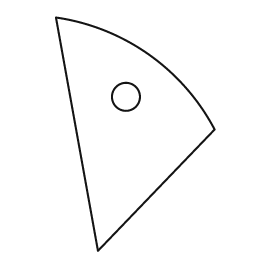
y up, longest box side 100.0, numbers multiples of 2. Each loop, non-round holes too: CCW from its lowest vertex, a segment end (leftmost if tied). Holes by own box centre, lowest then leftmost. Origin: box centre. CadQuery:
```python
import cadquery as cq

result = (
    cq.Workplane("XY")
    .moveTo(-16.0, -50.0)
    .lineTo(34.0, 2.0)
    .threePointArc((6.0, 34.0), (-34.0, 50.0))
    .close()
    .moveTo(-4.0, 16.0)
    .circle(6.0)
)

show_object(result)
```